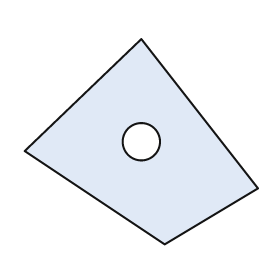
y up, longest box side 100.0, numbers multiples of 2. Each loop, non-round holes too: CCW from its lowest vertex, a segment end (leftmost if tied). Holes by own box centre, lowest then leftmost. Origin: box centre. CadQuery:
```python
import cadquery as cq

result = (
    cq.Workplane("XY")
    .moveTo(10.0, -44.0)
    .lineTo(50.0, -20.0)
    .lineTo(0.0, 44.0)
    .lineTo(-50.0, -4.0)
    .close()
    .moveTo(0.0, 0.0)
    .circle(8.0)
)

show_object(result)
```